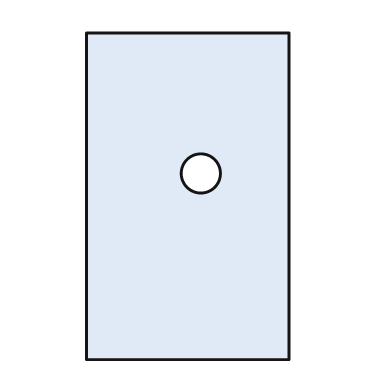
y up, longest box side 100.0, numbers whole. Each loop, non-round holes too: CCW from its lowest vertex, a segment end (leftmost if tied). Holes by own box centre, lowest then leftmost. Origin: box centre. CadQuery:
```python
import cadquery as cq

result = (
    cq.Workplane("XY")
    .moveTo(-31.0, -50.0)
    .lineTo(31.0, -50.0)
    .lineTo(31.0, 50.0)
    .lineTo(-31.0, 50.0)
    .close()
    .moveTo(4.0, 7.0)
    .circle(6.0)
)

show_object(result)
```